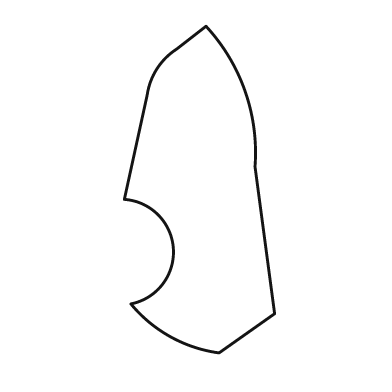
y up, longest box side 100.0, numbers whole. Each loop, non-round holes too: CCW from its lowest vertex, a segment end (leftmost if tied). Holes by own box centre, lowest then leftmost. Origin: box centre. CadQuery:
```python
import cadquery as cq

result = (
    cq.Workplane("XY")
    .moveTo(6.0, -50.0)
    .lineTo(23.0, -38.0)
    .lineTo(17.0, 7.0)
    .threePointArc((14.0, 30.0), (2.0, 50.0))
    .lineTo(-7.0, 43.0)
    .threePointArc((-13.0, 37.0), (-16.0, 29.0))
    .lineTo(-23.0, -3.0)
    .threePointArc((-8.0, -18.0), (-21.0, -35.0))
    .threePointArc((-9.0, -45.0), (6.0, -50.0))
    .close()
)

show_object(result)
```